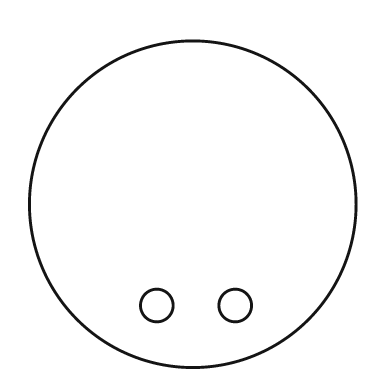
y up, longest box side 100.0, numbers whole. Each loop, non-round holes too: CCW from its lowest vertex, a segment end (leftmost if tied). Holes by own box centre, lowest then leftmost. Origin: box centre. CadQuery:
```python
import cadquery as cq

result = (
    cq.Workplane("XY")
    .moveTo(0.0, 0.0)
    .circle(50.0)
    .moveTo(-11.0, -31.0)
    .circle(5.0)
    .moveTo(13.0, -31.0)
    .circle(5.0)
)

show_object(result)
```